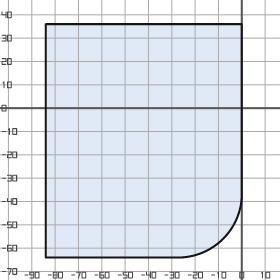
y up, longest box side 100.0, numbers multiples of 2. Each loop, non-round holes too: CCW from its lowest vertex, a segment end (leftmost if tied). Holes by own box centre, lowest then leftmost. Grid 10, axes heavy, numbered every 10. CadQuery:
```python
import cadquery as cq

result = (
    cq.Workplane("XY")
    .moveTo(-84.0, -64.0)
    .lineTo(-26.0, -64.0)
    .threePointArc((-8.0, -56.0), (0.0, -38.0))
    .lineTo(0.0, 36.0)
    .lineTo(-84.0, 36.0)
    .close()
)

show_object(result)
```